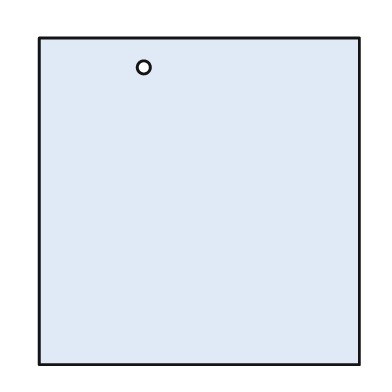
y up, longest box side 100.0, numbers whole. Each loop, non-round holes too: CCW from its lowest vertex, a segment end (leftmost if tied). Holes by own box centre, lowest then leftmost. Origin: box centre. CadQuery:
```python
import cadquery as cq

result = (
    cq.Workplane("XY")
    .moveTo(-49.0, -50.0)
    .lineTo(49.0, -50.0)
    .lineTo(49.0, 50.0)
    .lineTo(-49.0, 50.0)
    .close()
    .moveTo(-17.0, 41.0)
    .circle(2.0)
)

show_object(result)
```